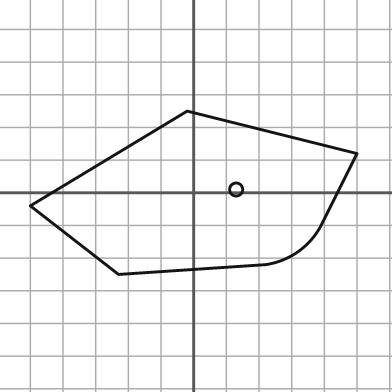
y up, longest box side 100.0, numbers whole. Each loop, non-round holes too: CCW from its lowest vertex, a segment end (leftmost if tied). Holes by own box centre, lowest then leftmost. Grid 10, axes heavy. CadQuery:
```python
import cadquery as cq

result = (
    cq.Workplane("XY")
    .moveTo(-23.0, -25.0)
    .lineTo(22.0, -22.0)
    .threePointArc((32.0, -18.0), (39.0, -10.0))
    .lineTo(50.0, 12.0)
    .lineTo(-2.0, 25.0)
    .lineTo(-50.0, -4.0)
    .close()
    .moveTo(13.0, 1.0)
    .circle(2.0)
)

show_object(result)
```